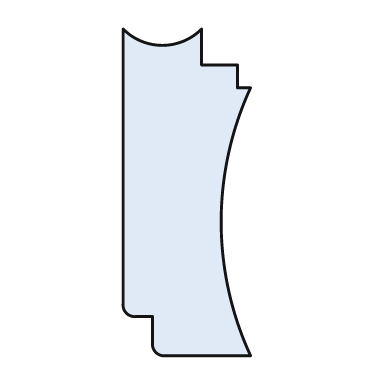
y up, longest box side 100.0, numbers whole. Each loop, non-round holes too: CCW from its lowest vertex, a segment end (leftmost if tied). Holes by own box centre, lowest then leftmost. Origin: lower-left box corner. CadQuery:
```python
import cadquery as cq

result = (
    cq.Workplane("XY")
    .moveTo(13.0, 0.0)
    .lineTo(39.0, 0.0)
    .threePointArc((30.0, 41.0), (39.0, 82.0))
    .lineTo(35.0, 82.0)
    .lineTo(35.0, 89.0)
    .lineTo(24.0, 89.0)
    .lineTo(24.0, 100.0)
    .threePointArc((12.0, 95.0), (0.0, 100.0))
    .lineTo(0.0, 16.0)
    .threePointArc((1.0, 13.0), (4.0, 12.0))
    .lineTo(9.0, 12.0)
    .lineTo(9.0, 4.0)
    .threePointArc((10.0, 1.0), (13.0, 0.0))
    .close()
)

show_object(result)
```